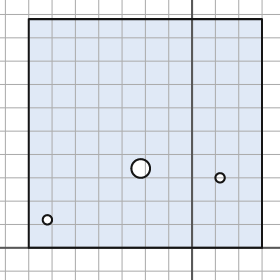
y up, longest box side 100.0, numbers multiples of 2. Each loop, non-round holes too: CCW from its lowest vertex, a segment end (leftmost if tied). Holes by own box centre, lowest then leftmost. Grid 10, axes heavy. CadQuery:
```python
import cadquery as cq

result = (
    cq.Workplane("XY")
    .moveTo(-70.0, 0.0)
    .lineTo(30.0, 0.0)
    .lineTo(30.0, 98.0)
    .lineTo(-70.0, 98.0)
    .close()
    .moveTo(-62.0, 12.0)
    .circle(2.0)
    .moveTo(12.0, 30.0)
    .circle(2.0)
    .moveTo(-22.0, 34.0)
    .circle(4.0)
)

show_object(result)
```